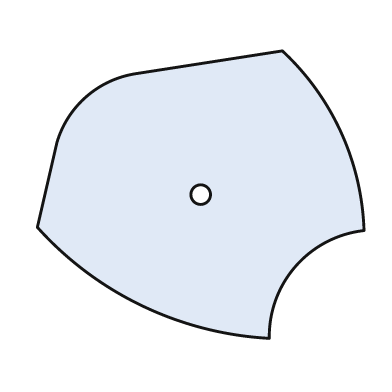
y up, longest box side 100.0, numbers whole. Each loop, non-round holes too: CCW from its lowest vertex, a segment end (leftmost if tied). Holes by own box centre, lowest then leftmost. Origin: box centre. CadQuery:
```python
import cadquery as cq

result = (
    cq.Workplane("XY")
    .moveTo(21.0, -44.0)
    .threePointArc((29.0, -22.0), (50.0, -11.0))
    .threePointArc((43.0, 19.0), (25.0, 44.0))
    .lineTo(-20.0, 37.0)
    .threePointArc((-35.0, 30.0), (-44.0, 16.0))
    .lineTo(-50.0, -10.0)
    .threePointArc((-18.0, -34.0), (21.0, -44.0))
    .close()
    .moveTo(0.0, 0.0)
    .circle(3.0)
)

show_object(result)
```